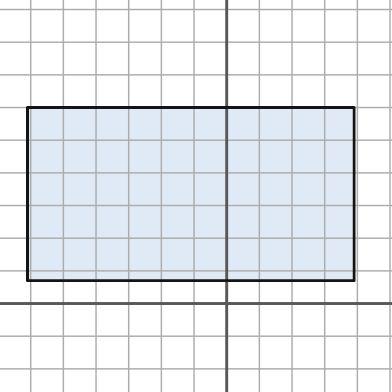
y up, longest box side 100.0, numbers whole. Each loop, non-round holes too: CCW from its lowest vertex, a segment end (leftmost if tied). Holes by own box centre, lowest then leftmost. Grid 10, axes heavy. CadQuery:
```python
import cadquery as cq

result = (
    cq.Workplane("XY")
    .moveTo(-61.0, 7.0)
    .lineTo(39.0, 7.0)
    .lineTo(39.0, 60.0)
    .lineTo(-61.0, 60.0)
    .close()
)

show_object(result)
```